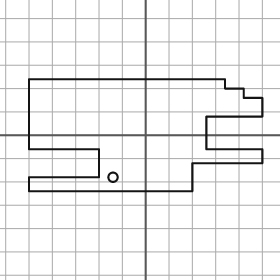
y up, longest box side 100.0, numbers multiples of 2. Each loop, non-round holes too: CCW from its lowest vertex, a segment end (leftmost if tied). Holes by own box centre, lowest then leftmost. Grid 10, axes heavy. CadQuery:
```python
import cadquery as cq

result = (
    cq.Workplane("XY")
    .moveTo(-50.0, -24.0)
    .lineTo(20.0, -24.0)
    .lineTo(20.0, -12.0)
    .lineTo(50.0, -12.0)
    .lineTo(50.0, -6.0)
    .lineTo(26.0, -6.0)
    .lineTo(26.0, 8.0)
    .lineTo(50.0, 8.0)
    .lineTo(50.0, 16.0)
    .lineTo(42.0, 16.0)
    .lineTo(42.0, 20.0)
    .lineTo(34.0, 20.0)
    .lineTo(34.0, 24.0)
    .lineTo(-50.0, 24.0)
    .lineTo(-50.0, -6.0)
    .lineTo(-20.0, -6.0)
    .lineTo(-20.0, -18.0)
    .lineTo(-50.0, -18.0)
    .close()
    .moveTo(-14.0, -18.0)
    .circle(2.0)
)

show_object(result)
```